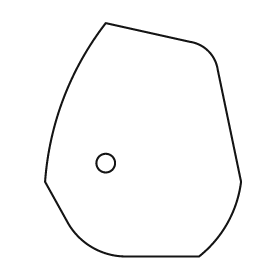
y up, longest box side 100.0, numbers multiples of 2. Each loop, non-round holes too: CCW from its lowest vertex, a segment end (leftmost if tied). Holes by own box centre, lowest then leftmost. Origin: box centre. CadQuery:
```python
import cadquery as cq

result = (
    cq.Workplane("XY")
    .moveTo(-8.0, -50.0)
    .lineTo(24.0, -50.0)
    .threePointArc((36.0, -36.0), (42.0, -18.0))
    .lineTo(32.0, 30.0)
    .threePointArc((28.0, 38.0), (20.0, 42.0))
    .lineTo(-16.0, 50.0)
    .threePointArc((-34.0, 18.0), (-42.0, -18.0))
    .lineTo(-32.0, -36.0)
    .threePointArc((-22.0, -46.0), (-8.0, -50.0))
    .close()
    .moveTo(-16.0, -10.0)
    .circle(4.0)
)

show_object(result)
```